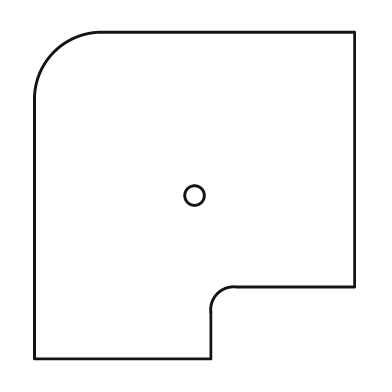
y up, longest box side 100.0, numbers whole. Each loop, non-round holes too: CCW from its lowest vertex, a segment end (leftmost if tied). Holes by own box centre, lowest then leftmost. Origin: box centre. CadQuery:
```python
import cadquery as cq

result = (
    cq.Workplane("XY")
    .moveTo(-49.0, -50.0)
    .lineTo(5.0, -50.0)
    .lineTo(5.0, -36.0)
    .threePointArc((7.0, -30.0), (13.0, -28.0))
    .lineTo(49.0, -28.0)
    .lineTo(49.0, 50.0)
    .lineTo(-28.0, 50.0)
    .threePointArc((-43.0, 44.0), (-49.0, 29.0))
    .close()
    .moveTo(0.0, 0.0)
    .circle(3.0)
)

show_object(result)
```